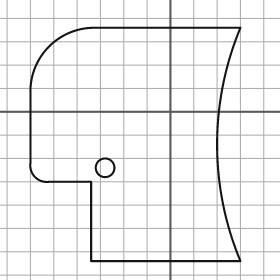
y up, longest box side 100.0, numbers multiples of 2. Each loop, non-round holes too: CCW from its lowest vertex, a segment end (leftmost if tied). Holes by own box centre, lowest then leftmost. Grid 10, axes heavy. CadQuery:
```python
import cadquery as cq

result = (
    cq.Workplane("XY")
    .moveTo(-34.0, -64.0)
    .lineTo(30.0, -64.0)
    .threePointArc((20.0, -14.0), (30.0, 36.0))
    .lineTo(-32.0, 36.0)
    .threePointArc((-52.0, 28.0), (-60.0, 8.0))
    .lineTo(-60.0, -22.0)
    .threePointArc((-58.0, -28.0), (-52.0, -30.0))
    .lineTo(-34.0, -30.0)
    .close()
    .moveTo(-28.0, -24.0)
    .circle(4.0)
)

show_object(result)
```